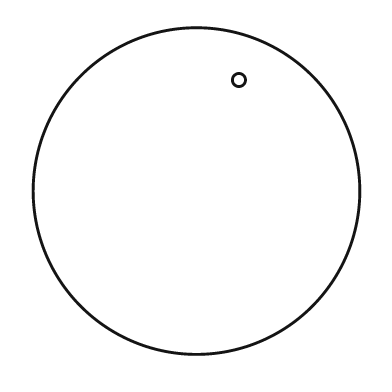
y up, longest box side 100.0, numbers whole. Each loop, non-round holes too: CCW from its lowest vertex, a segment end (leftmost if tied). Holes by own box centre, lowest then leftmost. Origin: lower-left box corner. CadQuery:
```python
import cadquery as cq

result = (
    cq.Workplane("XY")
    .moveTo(50.0, 50.0)
    .circle(50.0)
    .moveTo(63.0, 84.0)
    .circle(2.0)
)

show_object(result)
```